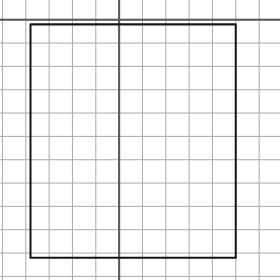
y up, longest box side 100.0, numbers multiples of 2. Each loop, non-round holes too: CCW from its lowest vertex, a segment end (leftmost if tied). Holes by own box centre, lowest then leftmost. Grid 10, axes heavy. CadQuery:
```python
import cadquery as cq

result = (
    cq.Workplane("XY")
    .moveTo(-38.0, -102.0)
    .lineTo(50.0, -102.0)
    .lineTo(50.0, -2.0)
    .lineTo(-38.0, -2.0)
    .close()
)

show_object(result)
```